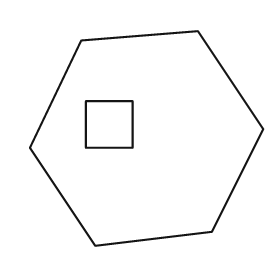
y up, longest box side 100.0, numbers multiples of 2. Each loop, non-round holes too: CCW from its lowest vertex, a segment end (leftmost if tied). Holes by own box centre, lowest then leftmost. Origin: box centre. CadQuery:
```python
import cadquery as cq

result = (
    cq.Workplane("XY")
    .moveTo(-22.0, -46.0)
    .lineTo(28.0, -40.0)
    .lineTo(50.0, 4.0)
    .lineTo(22.0, 46.0)
    .lineTo(-28.0, 42.0)
    .lineTo(-50.0, -4.0)
    .close()
    .moveTo(-26.0, -4.0)
    .lineTo(-6.0, -4.0)
    .lineTo(-6.0, 16.0)
    .lineTo(-26.0, 16.0)
    .close()
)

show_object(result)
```